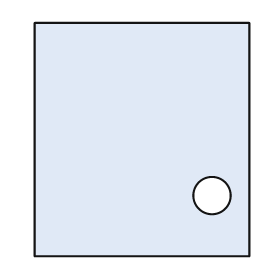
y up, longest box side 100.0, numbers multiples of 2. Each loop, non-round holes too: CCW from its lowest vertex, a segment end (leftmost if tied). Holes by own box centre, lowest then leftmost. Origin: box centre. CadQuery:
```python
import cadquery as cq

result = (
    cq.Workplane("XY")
    .moveTo(-46.0, -50.0)
    .lineTo(46.0, -50.0)
    .lineTo(46.0, 50.0)
    .lineTo(-46.0, 50.0)
    .close()
    .moveTo(30.0, -24.0)
    .circle(8.0)
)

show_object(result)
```